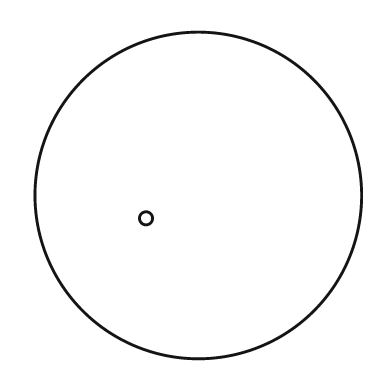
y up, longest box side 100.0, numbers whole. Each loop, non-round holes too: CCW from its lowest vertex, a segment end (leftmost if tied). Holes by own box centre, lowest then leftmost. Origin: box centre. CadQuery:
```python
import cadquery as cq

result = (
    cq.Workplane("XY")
    .moveTo(0.0, 0.0)
    .circle(50.0)
    .moveTo(-16.0, -7.0)
    .circle(2.0)
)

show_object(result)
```